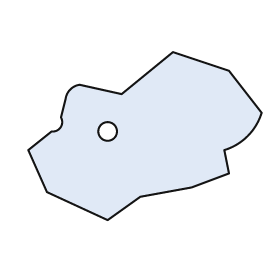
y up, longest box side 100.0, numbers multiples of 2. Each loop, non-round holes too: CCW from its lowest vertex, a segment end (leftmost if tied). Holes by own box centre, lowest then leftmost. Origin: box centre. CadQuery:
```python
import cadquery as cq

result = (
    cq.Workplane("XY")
    .moveTo(-16.0, -36.0)
    .lineTo(-2.0, -26.0)
    .lineTo(20.0, -22.0)
    .lineTo(36.0, -16.0)
    .lineTo(34.0, -6.0)
    .threePointArc((44.0, 0.0), (50.0, 10.0))
    .lineTo(36.0, 28.0)
    .lineTo(12.0, 36.0)
    .lineTo(-10.0, 18.0)
    .lineTo(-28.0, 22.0)
    .threePointArc((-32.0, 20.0), (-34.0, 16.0))
    .lineTo(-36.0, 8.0)
    .threePointArc((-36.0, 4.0), (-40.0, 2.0))
    .lineTo(-50.0, -6.0)
    .lineTo(-42.0, -24.0)
    .close()
    .moveTo(-16.0, 2.0)
    .circle(4.0)
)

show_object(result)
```